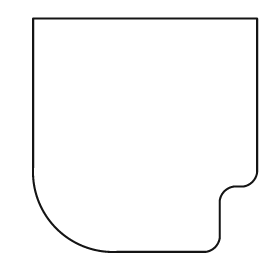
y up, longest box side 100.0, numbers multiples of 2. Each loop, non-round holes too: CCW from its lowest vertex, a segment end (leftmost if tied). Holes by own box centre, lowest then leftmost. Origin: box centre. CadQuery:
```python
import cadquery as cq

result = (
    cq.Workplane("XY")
    .moveTo(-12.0, -50.0)
    .lineTo(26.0, -50.0)
    .threePointArc((30.0, -48.0), (32.0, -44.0))
    .lineTo(32.0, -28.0)
    .threePointArc((34.0, -24.0), (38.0, -22.0))
    .lineTo(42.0, -22.0)
    .threePointArc((46.0, -20.0), (48.0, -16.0))
    .lineTo(48.0, 50.0)
    .lineTo(-48.0, 50.0)
    .lineTo(-48.0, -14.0)
    .threePointArc((-38.0, -40.0), (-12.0, -50.0))
    .close()
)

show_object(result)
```